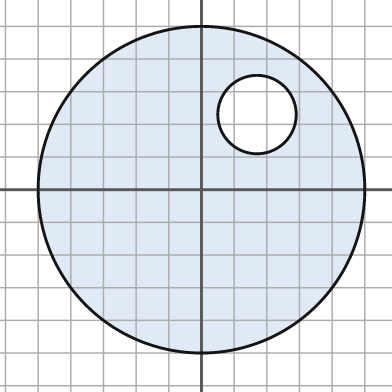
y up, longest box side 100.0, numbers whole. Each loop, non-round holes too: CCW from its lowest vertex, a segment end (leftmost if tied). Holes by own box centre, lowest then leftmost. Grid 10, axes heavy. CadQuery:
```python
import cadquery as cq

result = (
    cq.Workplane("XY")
    .moveTo(0.0, 0.0)
    .circle(50.0)
    .moveTo(17.0, 23.0)
    .circle(12.0)
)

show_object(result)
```